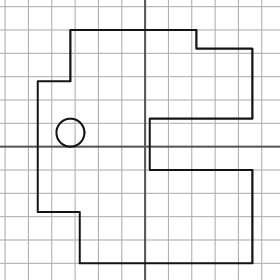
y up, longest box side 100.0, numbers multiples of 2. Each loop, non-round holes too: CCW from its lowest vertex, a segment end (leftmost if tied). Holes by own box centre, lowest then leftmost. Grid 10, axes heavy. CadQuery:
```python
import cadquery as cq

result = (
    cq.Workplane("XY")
    .moveTo(-28.0, -50.0)
    .lineTo(46.0, -50.0)
    .lineTo(46.0, -10.0)
    .lineTo(2.0, -10.0)
    .lineTo(2.0, 12.0)
    .lineTo(46.0, 12.0)
    .lineTo(46.0, 42.0)
    .lineTo(22.0, 42.0)
    .lineTo(22.0, 50.0)
    .lineTo(-32.0, 50.0)
    .lineTo(-32.0, 28.0)
    .lineTo(-46.0, 28.0)
    .lineTo(-46.0, -28.0)
    .lineTo(-28.0, -28.0)
    .close()
    .moveTo(-32.0, 6.0)
    .circle(6.0)
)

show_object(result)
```